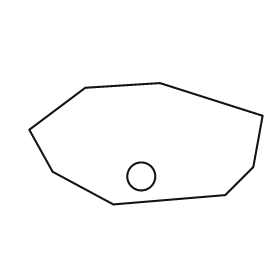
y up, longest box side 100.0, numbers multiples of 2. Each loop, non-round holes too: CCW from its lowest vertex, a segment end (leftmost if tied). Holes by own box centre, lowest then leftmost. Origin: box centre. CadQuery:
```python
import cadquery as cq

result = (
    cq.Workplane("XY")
    .moveTo(-14.0, -26.0)
    .lineTo(34.0, -22.0)
    .lineTo(46.0, -10.0)
    .lineTo(50.0, 12.0)
    .lineTo(6.0, 26.0)
    .lineTo(-26.0, 24.0)
    .lineTo(-50.0, 6.0)
    .lineTo(-40.0, -12.0)
    .close()
    .moveTo(-2.0, -14.0)
    .circle(6.0)
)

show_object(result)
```